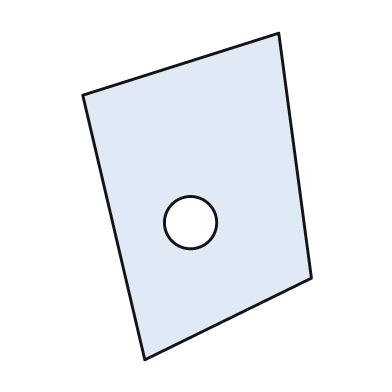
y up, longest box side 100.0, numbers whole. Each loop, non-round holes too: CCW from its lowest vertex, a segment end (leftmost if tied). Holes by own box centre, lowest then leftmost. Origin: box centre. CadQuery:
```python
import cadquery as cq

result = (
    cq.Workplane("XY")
    .moveTo(-16.0, -50.0)
    .lineTo(35.0, -25.0)
    .lineTo(25.0, 50.0)
    .lineTo(-35.0, 31.0)
    .close()
    .moveTo(-2.0, -8.0)
    .circle(8.0)
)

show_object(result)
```